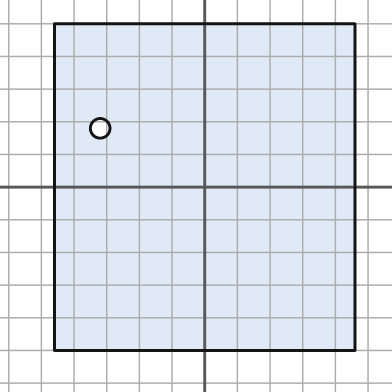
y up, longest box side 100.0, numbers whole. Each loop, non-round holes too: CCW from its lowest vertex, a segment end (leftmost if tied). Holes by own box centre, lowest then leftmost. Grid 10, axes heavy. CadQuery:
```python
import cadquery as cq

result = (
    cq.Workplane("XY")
    .moveTo(-46.0, -50.0)
    .lineTo(46.0, -50.0)
    .lineTo(46.0, 50.0)
    .lineTo(-46.0, 50.0)
    .close()
    .moveTo(-32.0, 18.0)
    .circle(3.0)
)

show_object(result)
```